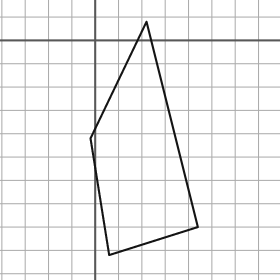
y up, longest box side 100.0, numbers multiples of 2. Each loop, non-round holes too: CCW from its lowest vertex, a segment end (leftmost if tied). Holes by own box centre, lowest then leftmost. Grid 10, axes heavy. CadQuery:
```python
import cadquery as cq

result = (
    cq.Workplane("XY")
    .moveTo(6.0, -92.0)
    .lineTo(44.0, -80.0)
    .lineTo(22.0, 8.0)
    .lineTo(-2.0, -42.0)
    .close()
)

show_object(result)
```